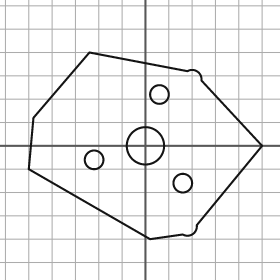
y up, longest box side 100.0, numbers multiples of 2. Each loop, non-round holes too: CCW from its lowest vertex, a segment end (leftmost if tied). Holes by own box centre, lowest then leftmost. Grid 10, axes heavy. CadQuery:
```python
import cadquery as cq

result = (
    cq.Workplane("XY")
    .moveTo(2.0, -40.0)
    .lineTo(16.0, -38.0)
    .threePointArc((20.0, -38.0), (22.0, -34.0))
    .lineTo(50.0, 0.0)
    .lineTo(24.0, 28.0)
    .threePointArc((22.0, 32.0), (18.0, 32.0))
    .lineTo(-24.0, 40.0)
    .lineTo(-48.0, 12.0)
    .lineTo(-50.0, -10.0)
    .close()
    .moveTo(16.0, -16.0)
    .circle(4.0)
    .moveTo(-22.0, -6.0)
    .circle(4.0)
    .moveTo(0.0, 0.0)
    .circle(8.0)
    .moveTo(6.0, 22.0)
    .circle(4.0)
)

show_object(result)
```